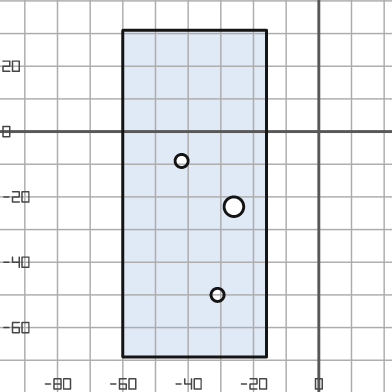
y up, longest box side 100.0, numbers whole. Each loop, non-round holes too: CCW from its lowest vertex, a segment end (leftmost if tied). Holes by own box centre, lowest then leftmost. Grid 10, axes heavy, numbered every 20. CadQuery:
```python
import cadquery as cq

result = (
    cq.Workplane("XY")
    .moveTo(-60.0, -69.0)
    .lineTo(-16.0, -69.0)
    .lineTo(-16.0, 31.0)
    .lineTo(-60.0, 31.0)
    .close()
    .moveTo(-31.0, -50.0)
    .circle(2.0)
    .moveTo(-26.0, -23.0)
    .circle(3.0)
    .moveTo(-42.0, -9.0)
    .circle(2.0)
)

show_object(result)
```